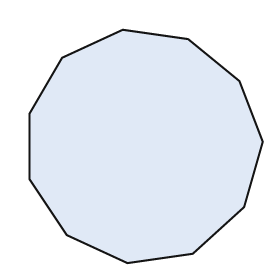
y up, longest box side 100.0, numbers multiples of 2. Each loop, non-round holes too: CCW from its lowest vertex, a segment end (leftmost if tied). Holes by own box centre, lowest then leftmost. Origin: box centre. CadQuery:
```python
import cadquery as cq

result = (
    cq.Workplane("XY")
    .moveTo(-8.0, -50.0)
    .lineTo(20.0, -46.0)
    .lineTo(42.0, -26.0)
    .lineTo(50.0, 2.0)
    .lineTo(40.0, 28.0)
    .lineTo(18.0, 46.0)
    .lineTo(-10.0, 50.0)
    .lineTo(-36.0, 38.0)
    .lineTo(-50.0, 14.0)
    .lineTo(-50.0, -14.0)
    .lineTo(-34.0, -38.0)
    .close()
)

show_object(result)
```